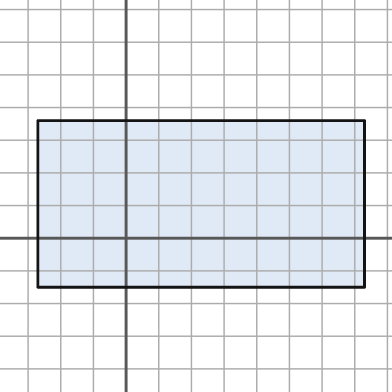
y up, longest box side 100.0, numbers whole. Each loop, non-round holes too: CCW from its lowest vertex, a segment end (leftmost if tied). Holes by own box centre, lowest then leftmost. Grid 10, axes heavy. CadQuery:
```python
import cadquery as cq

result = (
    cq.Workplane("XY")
    .moveTo(-27.0, -15.0)
    .lineTo(73.0, -15.0)
    .lineTo(73.0, 36.0)
    .lineTo(-27.0, 36.0)
    .close()
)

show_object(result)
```